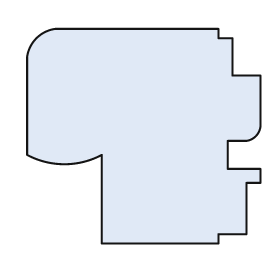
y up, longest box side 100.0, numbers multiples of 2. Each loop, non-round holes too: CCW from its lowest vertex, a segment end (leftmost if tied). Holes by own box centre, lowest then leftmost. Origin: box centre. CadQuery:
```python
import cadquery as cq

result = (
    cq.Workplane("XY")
    .moveTo(-18.0, -46.0)
    .lineTo(32.0, -46.0)
    .lineTo(32.0, -42.0)
    .lineTo(44.0, -42.0)
    .lineTo(44.0, -20.0)
    .lineTo(50.0, -20.0)
    .lineTo(50.0, -14.0)
    .lineTo(36.0, -14.0)
    .lineTo(36.0, -2.0)
    .lineTo(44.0, -2.0)
    .threePointArc((48.0, 0.0), (50.0, 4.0))
    .lineTo(50.0, 26.0)
    .lineTo(38.0, 26.0)
    .lineTo(38.0, 42.0)
    .lineTo(32.0, 42.0)
    .lineTo(32.0, 46.0)
    .lineTo(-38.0, 46.0)
    .threePointArc((-46.0, 42.0), (-50.0, 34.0))
    .lineTo(-50.0, -8.0)
    .threePointArc((-34.0, -12.0), (-18.0, -8.0))
    .close()
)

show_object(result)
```